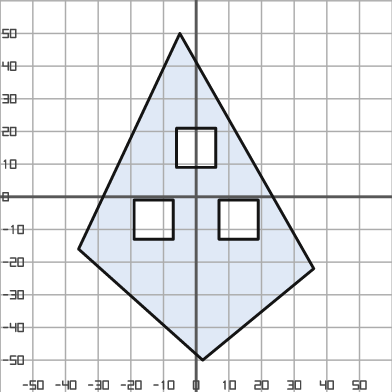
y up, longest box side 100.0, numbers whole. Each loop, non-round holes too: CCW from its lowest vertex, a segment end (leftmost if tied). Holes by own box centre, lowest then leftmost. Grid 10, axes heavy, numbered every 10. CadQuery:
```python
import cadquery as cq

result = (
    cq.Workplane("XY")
    .moveTo(2.0, -50.0)
    .lineTo(36.0, -22.0)
    .lineTo(-5.0, 50.0)
    .lineTo(-36.0, -16.0)
    .close()
    .moveTo(-19.0, -13.0)
    .lineTo(-7.0, -13.0)
    .lineTo(-7.0, -1.0)
    .lineTo(-19.0, -1.0)
    .close()
    .moveTo(7.0, -13.0)
    .lineTo(19.0, -13.0)
    .lineTo(19.0, -1.0)
    .lineTo(7.0, -1.0)
    .close()
    .moveTo(-6.0, 9.0)
    .lineTo(6.0, 9.0)
    .lineTo(6.0, 21.0)
    .lineTo(-6.0, 21.0)
    .close()
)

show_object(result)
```